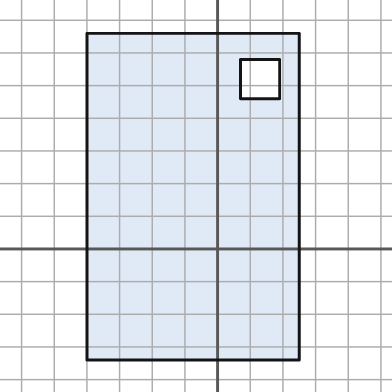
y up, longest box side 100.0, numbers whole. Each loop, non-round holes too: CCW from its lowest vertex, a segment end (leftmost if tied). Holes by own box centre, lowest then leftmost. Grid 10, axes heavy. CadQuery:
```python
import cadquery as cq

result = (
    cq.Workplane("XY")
    .moveTo(-40.0, -34.0)
    .lineTo(25.0, -34.0)
    .lineTo(25.0, 66.0)
    .lineTo(-40.0, 66.0)
    .close()
    .moveTo(7.0, 46.0)
    .lineTo(19.0, 46.0)
    .lineTo(19.0, 58.0)
    .lineTo(7.0, 58.0)
    .close()
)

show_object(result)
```